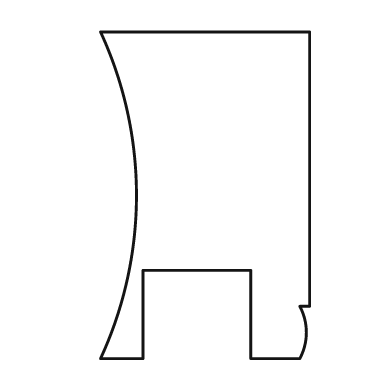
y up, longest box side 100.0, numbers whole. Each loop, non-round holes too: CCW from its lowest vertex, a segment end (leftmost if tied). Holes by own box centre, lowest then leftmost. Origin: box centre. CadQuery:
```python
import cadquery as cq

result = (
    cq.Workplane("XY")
    .moveTo(-32.0, -50.0)
    .lineTo(-19.0, -50.0)
    .lineTo(-19.0, -23.0)
    .lineTo(14.0, -23.0)
    .lineTo(14.0, -50.0)
    .lineTo(29.0, -50.0)
    .threePointArc((31.0, -42.0), (29.0, -34.0))
    .lineTo(32.0, -34.0)
    .lineTo(32.0, 50.0)
    .lineTo(-32.0, 50.0)
    .threePointArc((-21.0, 0.0), (-32.0, -50.0))
    .close()
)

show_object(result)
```